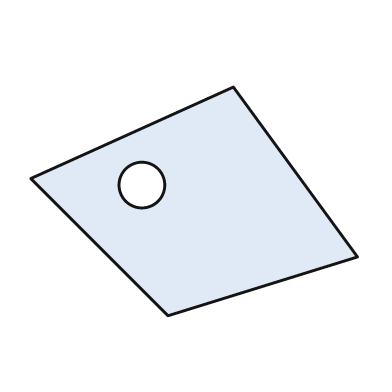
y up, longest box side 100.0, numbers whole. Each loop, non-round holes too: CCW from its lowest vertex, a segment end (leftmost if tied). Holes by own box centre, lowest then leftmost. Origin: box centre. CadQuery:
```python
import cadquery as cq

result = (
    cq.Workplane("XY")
    .moveTo(-8.0, -35.0)
    .lineTo(50.0, -17.0)
    .lineTo(12.0, 35.0)
    .lineTo(-50.0, 7.0)
    .close()
    .moveTo(-16.0, 5.0)
    .circle(7.0)
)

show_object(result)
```